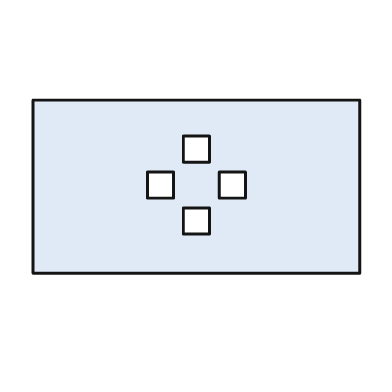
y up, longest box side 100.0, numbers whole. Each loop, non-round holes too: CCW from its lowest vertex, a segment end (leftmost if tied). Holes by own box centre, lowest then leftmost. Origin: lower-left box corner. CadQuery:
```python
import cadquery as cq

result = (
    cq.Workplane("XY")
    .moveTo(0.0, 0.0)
    .lineTo(100.0, 0.0)
    .lineTo(100.0, 53.0)
    .lineTo(0.0, 53.0)
    .close()
    .moveTo(46.0, 12.0)
    .lineTo(54.0, 12.0)
    .lineTo(54.0, 20.0)
    .lineTo(46.0, 20.0)
    .close()
    .moveTo(35.0, 23.0)
    .lineTo(43.0, 23.0)
    .lineTo(43.0, 31.0)
    .lineTo(35.0, 31.0)
    .close()
    .moveTo(57.0, 23.0)
    .lineTo(65.0, 23.0)
    .lineTo(65.0, 31.0)
    .lineTo(57.0, 31.0)
    .close()
    .moveTo(46.0, 34.0)
    .lineTo(54.0, 34.0)
    .lineTo(54.0, 42.0)
    .lineTo(46.0, 42.0)
    .close()
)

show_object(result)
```